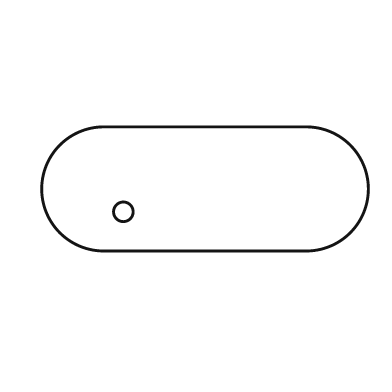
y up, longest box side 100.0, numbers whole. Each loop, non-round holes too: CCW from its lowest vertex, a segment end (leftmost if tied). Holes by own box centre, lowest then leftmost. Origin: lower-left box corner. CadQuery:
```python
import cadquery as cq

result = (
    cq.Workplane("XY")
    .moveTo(19.0, 0.0)
    .lineTo(81.0, 0.0)
    .threePointArc((100.0, 19.0), (81.0, 38.0))
    .lineTo(19.0, 38.0)
    .threePointArc((0.0, 19.0), (19.0, 0.0))
    .close()
    .moveTo(25.0, 12.0)
    .circle(3.0)
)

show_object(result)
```